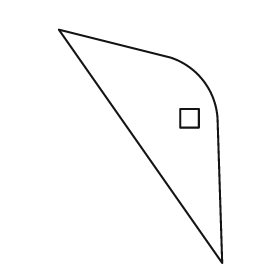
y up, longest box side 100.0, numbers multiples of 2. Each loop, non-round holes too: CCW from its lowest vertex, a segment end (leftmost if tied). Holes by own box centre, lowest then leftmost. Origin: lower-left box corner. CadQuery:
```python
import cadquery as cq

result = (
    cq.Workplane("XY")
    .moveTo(70.0, 0.0)
    .lineTo(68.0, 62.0)
    .threePointArc((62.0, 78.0), (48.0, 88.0))
    .lineTo(0.0, 100.0)
    .close()
    .moveTo(52.0, 58.0)
    .lineTo(60.0, 58.0)
    .lineTo(60.0, 66.0)
    .lineTo(52.0, 66.0)
    .close()
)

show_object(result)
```